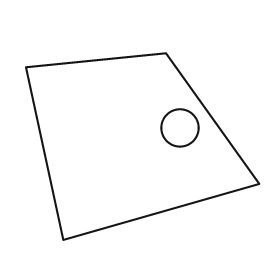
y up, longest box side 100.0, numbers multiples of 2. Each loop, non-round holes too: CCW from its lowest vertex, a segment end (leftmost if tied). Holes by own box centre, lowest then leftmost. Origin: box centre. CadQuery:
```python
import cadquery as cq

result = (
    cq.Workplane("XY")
    .moveTo(-34.0, -40.0)
    .lineTo(50.0, -16.0)
    .lineTo(10.0, 40.0)
    .lineTo(-50.0, 34.0)
    .close()
    .moveTo(16.0, 8.0)
    .circle(8.0)
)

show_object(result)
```